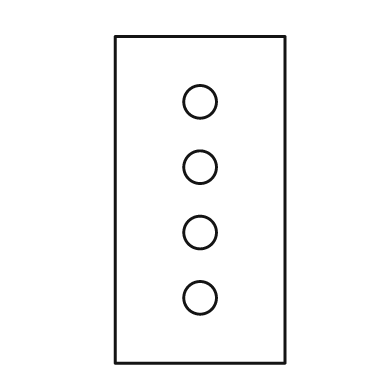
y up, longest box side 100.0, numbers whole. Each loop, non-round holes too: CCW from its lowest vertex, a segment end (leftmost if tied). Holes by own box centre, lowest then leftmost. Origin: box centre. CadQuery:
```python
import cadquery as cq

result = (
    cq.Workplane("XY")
    .moveTo(-26.0, -50.0)
    .lineTo(26.0, -50.0)
    .lineTo(26.0, 50.0)
    .lineTo(-26.0, 50.0)
    .close()
    .moveTo(0.0, -30.0)
    .circle(5.0)
    .moveTo(0.0, -10.0)
    .circle(5.0)
    .moveTo(0.0, 10.0)
    .circle(5.0)
    .moveTo(0.0, 30.0)
    .circle(5.0)
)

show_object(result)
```